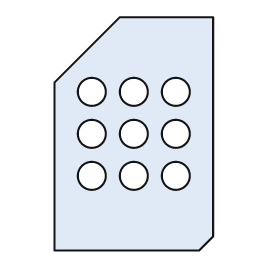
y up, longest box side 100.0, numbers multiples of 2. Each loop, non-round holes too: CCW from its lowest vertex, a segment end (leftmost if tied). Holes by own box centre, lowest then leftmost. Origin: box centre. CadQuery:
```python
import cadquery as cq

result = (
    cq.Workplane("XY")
    .moveTo(-34.0, -50.0)
    .lineTo(28.0, -50.0)
    .lineTo(34.0, -44.0)
    .lineTo(34.0, 50.0)
    .lineTo(-6.0, 50.0)
    .lineTo(-34.0, 22.0)
    .close()
    .moveTo(-18.0, -18.0)
    .circle(6.0)
    .moveTo(0.0, -18.0)
    .circle(6.0)
    .moveTo(18.0, -18.0)
    .circle(6.0)
    .moveTo(-18.0, 0.0)
    .circle(6.0)
    .moveTo(0.0, 0.0)
    .circle(6.0)
    .moveTo(18.0, 0.0)
    .circle(6.0)
    .moveTo(-18.0, 18.0)
    .circle(6.0)
    .moveTo(0.0, 18.0)
    .circle(6.0)
    .moveTo(18.0, 18.0)
    .circle(6.0)
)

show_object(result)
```